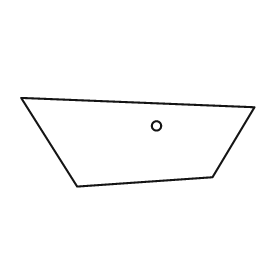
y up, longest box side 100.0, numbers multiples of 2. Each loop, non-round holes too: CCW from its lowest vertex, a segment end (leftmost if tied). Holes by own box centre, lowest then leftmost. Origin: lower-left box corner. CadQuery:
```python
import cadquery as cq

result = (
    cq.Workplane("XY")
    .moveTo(24.0, 0.0)
    .lineTo(82.0, 4.0)
    .lineTo(100.0, 34.0)
    .lineTo(0.0, 38.0)
    .close()
    .moveTo(58.0, 26.0)
    .circle(2.0)
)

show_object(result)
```